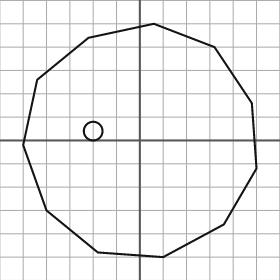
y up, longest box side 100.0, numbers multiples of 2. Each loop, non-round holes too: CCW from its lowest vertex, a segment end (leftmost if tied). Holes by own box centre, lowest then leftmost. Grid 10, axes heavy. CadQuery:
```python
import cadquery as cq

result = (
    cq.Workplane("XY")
    .moveTo(10.0, -50.0)
    .lineTo(36.0, -36.0)
    .lineTo(50.0, -12.0)
    .lineTo(48.0, 16.0)
    .lineTo(32.0, 40.0)
    .lineTo(6.0, 50.0)
    .lineTo(-22.0, 44.0)
    .lineTo(-44.0, 26.0)
    .lineTo(-50.0, -2.0)
    .lineTo(-40.0, -30.0)
    .lineTo(-18.0, -48.0)
    .close()
    .moveTo(-20.0, 4.0)
    .circle(4.0)
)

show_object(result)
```